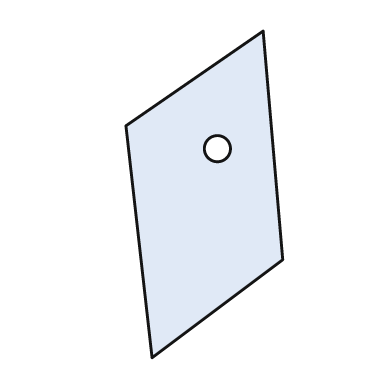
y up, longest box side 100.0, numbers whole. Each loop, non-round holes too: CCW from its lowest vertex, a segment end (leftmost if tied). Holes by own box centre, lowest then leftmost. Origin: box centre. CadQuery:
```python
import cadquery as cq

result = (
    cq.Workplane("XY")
    .moveTo(-16.0, -50.0)
    .lineTo(24.0, -20.0)
    .lineTo(18.0, 50.0)
    .lineTo(-24.0, 21.0)
    .close()
    .moveTo(4.0, 14.0)
    .circle(4.0)
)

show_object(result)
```